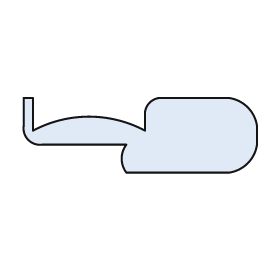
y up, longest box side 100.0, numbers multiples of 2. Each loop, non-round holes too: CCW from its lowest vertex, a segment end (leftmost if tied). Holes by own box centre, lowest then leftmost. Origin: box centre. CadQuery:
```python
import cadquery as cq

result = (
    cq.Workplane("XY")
    .moveTo(-6.0, -16.0)
    .lineTo(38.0, -16.0)
    .threePointArc((46.0, -12.0), (50.0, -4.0))
    .lineTo(50.0, 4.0)
    .threePointArc((46.0, 12.0), (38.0, 16.0))
    .lineTo(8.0, 16.0)
    .threePointArc((4.0, 14.0), (2.0, 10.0))
    .lineTo(2.0, 2.0)
    .threePointArc((-22.0, 8.0), (-46.0, 2.0))
    .lineTo(-46.0, 16.0)
    .lineTo(-50.0, 16.0)
    .lineTo(-50.0, 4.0)
    .threePointArc((-48.0, -2.0), (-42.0, -4.0))
    .lineTo(-6.0, -4.0)
    .threePointArc((-8.0, -10.0), (-6.0, -16.0))
    .close()
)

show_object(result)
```